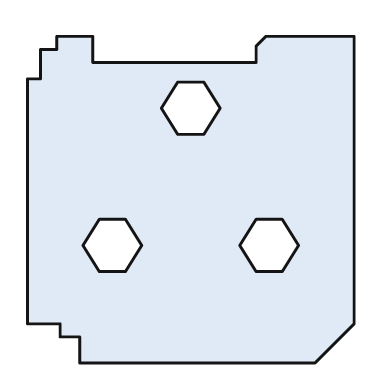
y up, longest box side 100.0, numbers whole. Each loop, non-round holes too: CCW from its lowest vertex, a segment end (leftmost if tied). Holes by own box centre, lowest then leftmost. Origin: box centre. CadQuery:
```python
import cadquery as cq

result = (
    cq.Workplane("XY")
    .moveTo(-34.0, -50.0)
    .lineTo(38.0, -50.0)
    .lineTo(50.0, -38.0)
    .lineTo(50.0, 50.0)
    .lineTo(23.0, 50.0)
    .lineTo(20.0, 47.0)
    .lineTo(20.0, 42.0)
    .lineTo(-30.0, 42.0)
    .lineTo(-30.0, 50.0)
    .lineTo(-41.0, 50.0)
    .lineTo(-41.0, 46.0)
    .lineTo(-46.0, 46.0)
    .lineTo(-46.0, 37.0)
    .lineTo(-50.0, 37.0)
    .lineTo(-50.0, -38.0)
    .lineTo(-40.0, -38.0)
    .lineTo(-40.0, -42.0)
    .lineTo(-34.0, -42.0)
    .close()
    .moveTo(-28.0, -22.0)
    .lineTo(-20.0, -22.0)
    .lineTo(-15.0, -14.0)
    .lineTo(-20.0, -6.0)
    .lineTo(-28.0, -6.0)
    .lineTo(-33.0, -14.0)
    .close()
    .moveTo(20.0, -22.0)
    .lineTo(28.0, -22.0)
    .lineTo(33.0, -14.0)
    .lineTo(28.0, -6.0)
    .lineTo(20.0, -6.0)
    .lineTo(15.0, -14.0)
    .close()
    .moveTo(-4.0, 20.0)
    .lineTo(4.0, 20.0)
    .lineTo(9.0, 28.0)
    .lineTo(4.0, 36.0)
    .lineTo(-4.0, 36.0)
    .lineTo(-9.0, 28.0)
    .close()
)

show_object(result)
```